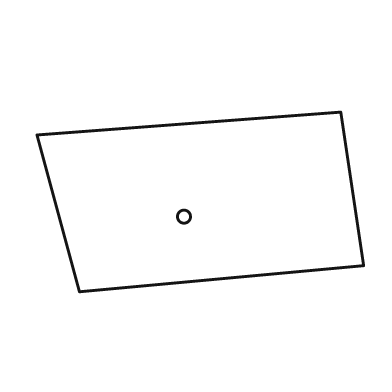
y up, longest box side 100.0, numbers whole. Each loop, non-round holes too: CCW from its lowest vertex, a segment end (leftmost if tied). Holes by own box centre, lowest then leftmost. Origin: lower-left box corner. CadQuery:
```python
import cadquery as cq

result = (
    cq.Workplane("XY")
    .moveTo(13.0, 0.0)
    .lineTo(100.0, 8.0)
    .lineTo(93.0, 55.0)
    .lineTo(0.0, 48.0)
    .close()
    .moveTo(45.0, 23.0)
    .circle(2.0)
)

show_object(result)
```